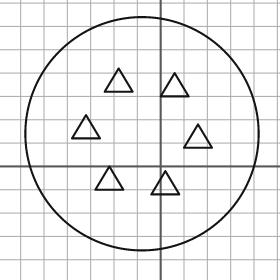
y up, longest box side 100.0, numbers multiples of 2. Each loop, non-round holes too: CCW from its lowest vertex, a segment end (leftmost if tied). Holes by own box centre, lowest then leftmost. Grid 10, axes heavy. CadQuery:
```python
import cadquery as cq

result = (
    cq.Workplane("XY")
    .moveTo(-8.0, 14.0)
    .circle(50.0)
    .moveTo(-4.0, -12.0)
    .lineTo(8.0, -12.0)
    .lineTo(2.0, -2.0)
    .close()
    .moveTo(-28.0, -10.0)
    .lineTo(-16.0, -10.0)
    .lineTo(-22.0, 0.0)
    .close()
    .moveTo(10.0, 8.0)
    .lineTo(22.0, 8.0)
    .lineTo(16.0, 18.0)
    .close()
    .moveTo(-38.0, 12.0)
    .lineTo(-26.0, 12.0)
    .lineTo(-32.0, 22.0)
    .close()
    .moveTo(0.0, 30.0)
    .lineTo(12.0, 30.0)
    .lineTo(6.0, 40.0)
    .close()
    .moveTo(-24.0, 32.0)
    .lineTo(-12.0, 32.0)
    .lineTo(-18.0, 42.0)
    .close()
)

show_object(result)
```